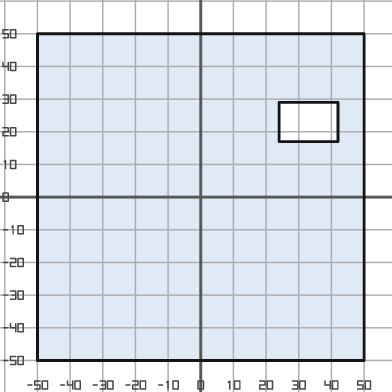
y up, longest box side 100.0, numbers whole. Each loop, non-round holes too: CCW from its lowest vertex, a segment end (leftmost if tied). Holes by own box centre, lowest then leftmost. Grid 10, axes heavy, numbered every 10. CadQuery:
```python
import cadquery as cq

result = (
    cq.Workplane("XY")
    .moveTo(-50.0, -50.0)
    .lineTo(50.0, -50.0)
    .lineTo(50.0, 50.0)
    .lineTo(-50.0, 50.0)
    .close()
    .moveTo(24.0, 17.0)
    .lineTo(42.0, 17.0)
    .lineTo(42.0, 29.0)
    .lineTo(24.0, 29.0)
    .close()
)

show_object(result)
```